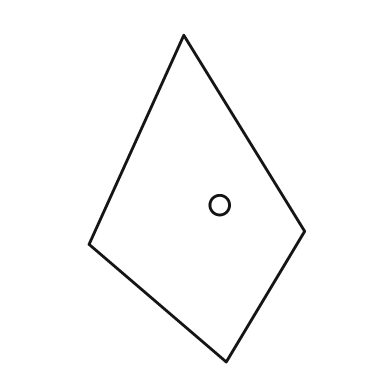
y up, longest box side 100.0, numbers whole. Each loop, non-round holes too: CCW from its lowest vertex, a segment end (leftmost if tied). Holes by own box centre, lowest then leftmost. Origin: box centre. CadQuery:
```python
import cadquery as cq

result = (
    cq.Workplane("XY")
    .moveTo(9.0, -50.0)
    .lineTo(33.0, -10.0)
    .lineTo(-4.0, 50.0)
    .lineTo(-33.0, -14.0)
    .close()
    .moveTo(7.0, -2.0)
    .circle(3.0)
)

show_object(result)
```